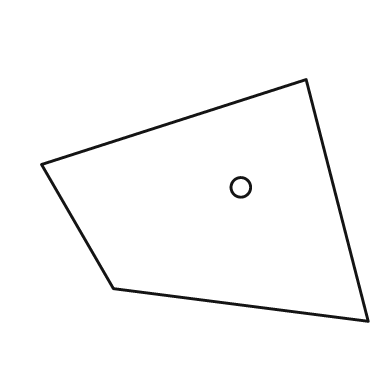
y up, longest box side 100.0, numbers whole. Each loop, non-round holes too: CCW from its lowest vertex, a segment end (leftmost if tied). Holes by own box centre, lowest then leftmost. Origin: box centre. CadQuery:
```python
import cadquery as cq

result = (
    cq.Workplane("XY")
    .moveTo(50.0, -37.0)
    .lineTo(31.0, 37.0)
    .lineTo(-50.0, 11.0)
    .lineTo(-28.0, -27.0)
    .close()
    .moveTo(11.0, 4.0)
    .circle(3.0)
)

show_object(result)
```